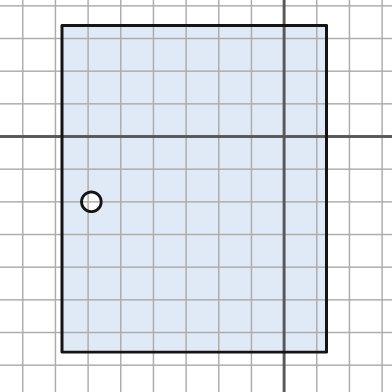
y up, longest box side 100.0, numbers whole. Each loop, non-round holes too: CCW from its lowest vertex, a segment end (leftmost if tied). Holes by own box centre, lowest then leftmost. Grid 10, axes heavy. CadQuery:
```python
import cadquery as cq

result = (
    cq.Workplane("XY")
    .moveTo(-68.0, -66.0)
    .lineTo(13.0, -66.0)
    .lineTo(13.0, 34.0)
    .lineTo(-68.0, 34.0)
    .close()
    .moveTo(-59.0, -20.0)
    .circle(3.0)
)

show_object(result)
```